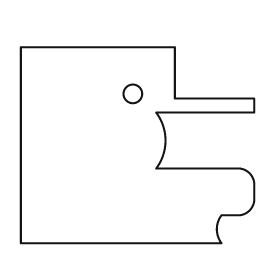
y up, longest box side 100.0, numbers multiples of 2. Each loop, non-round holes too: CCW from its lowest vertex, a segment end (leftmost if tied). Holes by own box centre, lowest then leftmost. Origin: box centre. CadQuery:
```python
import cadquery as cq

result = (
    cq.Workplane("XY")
    .moveTo(-50.0, -42.0)
    .lineTo(36.0, -42.0)
    .threePointArc((34.0, -36.0), (36.0, -30.0))
    .lineTo(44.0, -30.0)
    .threePointArc((48.0, -28.0), (50.0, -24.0))
    .lineTo(50.0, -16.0)
    .threePointArc((48.0, -12.0), (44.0, -10.0))
    .lineTo(8.0, -10.0)
    .threePointArc((12.0, 2.0), (8.0, 14.0))
    .lineTo(50.0, 14.0)
    .lineTo(50.0, 20.0)
    .lineTo(16.0, 20.0)
    .lineTo(16.0, 42.0)
    .lineTo(-50.0, 42.0)
    .close()
    .moveTo(-2.0, 22.0)
    .circle(4.0)
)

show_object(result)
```